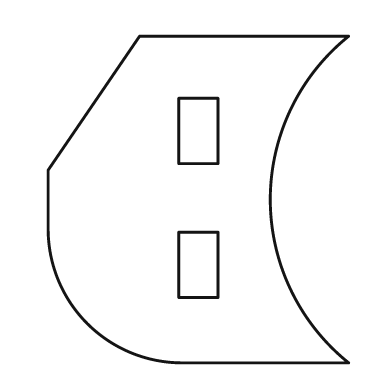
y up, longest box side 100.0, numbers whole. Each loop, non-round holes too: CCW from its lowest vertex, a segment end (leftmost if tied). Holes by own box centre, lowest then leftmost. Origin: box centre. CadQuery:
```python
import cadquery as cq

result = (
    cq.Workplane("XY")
    .moveTo(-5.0, -50.0)
    .lineTo(46.0, -50.0)
    .threePointArc((22.0, 0.0), (46.0, 50.0))
    .lineTo(-18.0, 50.0)
    .lineTo(-46.0, 9.0)
    .lineTo(-46.0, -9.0)
    .threePointArc((-34.0, -38.0), (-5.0, -50.0))
    .close()
    .moveTo(-6.0, -30.0)
    .lineTo(6.0, -30.0)
    .lineTo(6.0, -10.0)
    .lineTo(-6.0, -10.0)
    .close()
    .moveTo(-6.0, 11.0)
    .lineTo(6.0, 11.0)
    .lineTo(6.0, 31.0)
    .lineTo(-6.0, 31.0)
    .close()
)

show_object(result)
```